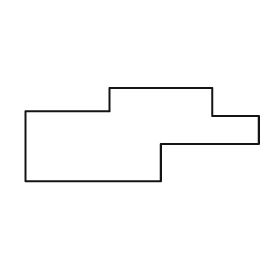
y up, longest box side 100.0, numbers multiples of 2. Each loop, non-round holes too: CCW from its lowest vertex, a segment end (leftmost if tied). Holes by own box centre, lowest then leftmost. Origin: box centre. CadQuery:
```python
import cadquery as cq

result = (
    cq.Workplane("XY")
    .moveTo(-50.0, -20.0)
    .lineTo(8.0, -20.0)
    .lineTo(8.0, -4.0)
    .lineTo(50.0, -4.0)
    .lineTo(50.0, 8.0)
    .lineTo(30.0, 8.0)
    .lineTo(30.0, 20.0)
    .lineTo(-14.0, 20.0)
    .lineTo(-14.0, 10.0)
    .lineTo(-50.0, 10.0)
    .close()
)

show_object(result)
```